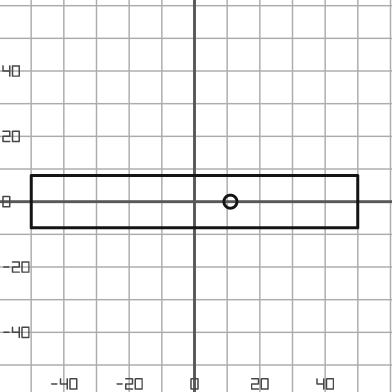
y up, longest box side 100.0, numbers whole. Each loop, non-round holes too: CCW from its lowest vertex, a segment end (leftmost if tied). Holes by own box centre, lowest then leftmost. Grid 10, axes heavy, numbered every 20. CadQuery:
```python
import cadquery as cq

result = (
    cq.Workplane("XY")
    .moveTo(-50.0, -8.0)
    .lineTo(50.0, -8.0)
    .lineTo(50.0, 8.0)
    .lineTo(-50.0, 8.0)
    .close()
    .moveTo(11.0, 0.0)
    .circle(2.0)
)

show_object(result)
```